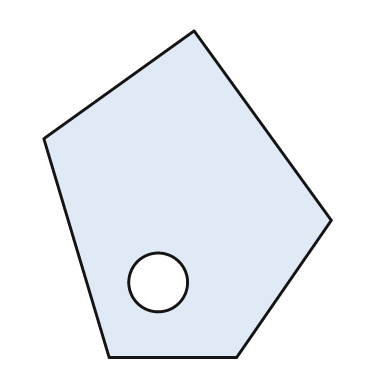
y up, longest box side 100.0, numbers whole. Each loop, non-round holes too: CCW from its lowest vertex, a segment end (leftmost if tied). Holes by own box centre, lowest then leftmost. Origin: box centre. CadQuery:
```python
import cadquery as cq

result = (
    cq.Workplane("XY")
    .moveTo(-24.0, -50.0)
    .lineTo(15.0, -50.0)
    .lineTo(44.0, -8.0)
    .lineTo(2.0, 50.0)
    .lineTo(-44.0, 17.0)
    .close()
    .moveTo(-9.0, -27.0)
    .circle(9.0)
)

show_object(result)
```